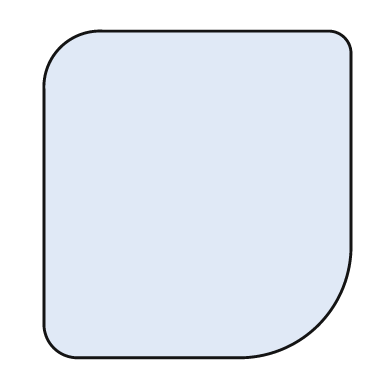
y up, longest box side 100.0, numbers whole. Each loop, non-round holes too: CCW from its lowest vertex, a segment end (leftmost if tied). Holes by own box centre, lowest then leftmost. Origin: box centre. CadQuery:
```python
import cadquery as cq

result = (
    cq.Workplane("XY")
    .moveTo(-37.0, -50.0)
    .lineTo(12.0, -50.0)
    .threePointArc((37.0, -40.0), (47.0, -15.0))
    .lineTo(47.0, 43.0)
    .threePointArc((45.0, 48.0), (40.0, 50.0))
    .lineTo(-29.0, 50.0)
    .threePointArc((-42.0, 45.0), (-47.0, 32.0))
    .lineTo(-47.0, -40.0)
    .threePointArc((-44.0, -47.0), (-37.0, -50.0))
    .close()
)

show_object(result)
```